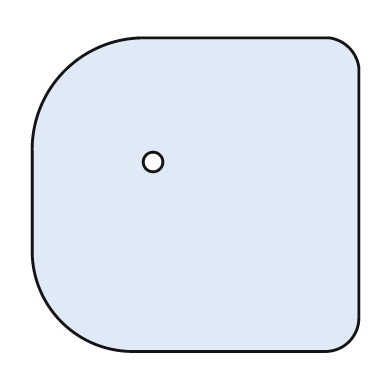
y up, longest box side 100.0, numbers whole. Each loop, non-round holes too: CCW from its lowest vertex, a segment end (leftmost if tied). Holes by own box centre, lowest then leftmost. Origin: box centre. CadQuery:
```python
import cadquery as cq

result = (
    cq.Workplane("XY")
    .moveTo(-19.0, -48.0)
    .lineTo(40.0, -48.0)
    .threePointArc((47.0, -45.0), (50.0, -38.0))
    .lineTo(50.0, 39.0)
    .threePointArc((47.0, 45.0), (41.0, 48.0))
    .lineTo(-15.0, 48.0)
    .threePointArc((-40.0, 38.0), (-50.0, 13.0))
    .lineTo(-50.0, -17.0)
    .threePointArc((-41.0, -39.0), (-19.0, -48.0))
    .close()
    .moveTo(-13.0, 10.0)
    .circle(3.0)
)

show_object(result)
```